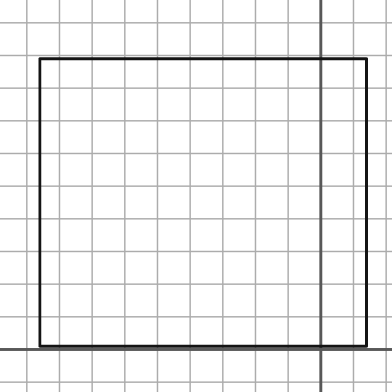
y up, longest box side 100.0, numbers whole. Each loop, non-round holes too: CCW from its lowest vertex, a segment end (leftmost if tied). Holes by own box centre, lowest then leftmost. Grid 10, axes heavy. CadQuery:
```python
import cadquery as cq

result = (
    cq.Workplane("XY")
    .moveTo(-86.0, 1.0)
    .lineTo(14.0, 1.0)
    .lineTo(14.0, 89.0)
    .lineTo(-86.0, 89.0)
    .close()
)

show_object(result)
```